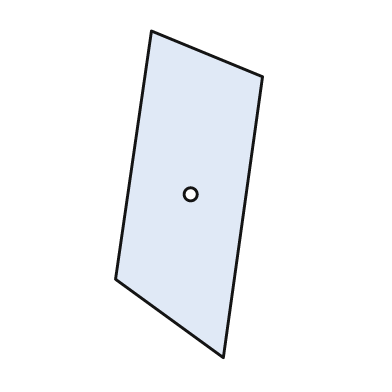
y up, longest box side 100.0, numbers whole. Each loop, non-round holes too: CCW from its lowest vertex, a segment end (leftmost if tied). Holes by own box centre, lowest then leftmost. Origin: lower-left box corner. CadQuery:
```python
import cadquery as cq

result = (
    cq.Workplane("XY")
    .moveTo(33.0, 0.0)
    .lineTo(45.0, 86.0)
    .lineTo(11.0, 100.0)
    .lineTo(0.0, 24.0)
    .close()
    .moveTo(23.0, 50.0)
    .circle(2.0)
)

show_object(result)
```